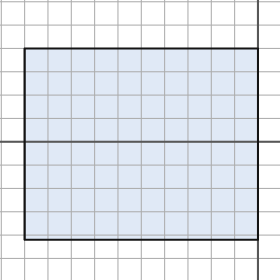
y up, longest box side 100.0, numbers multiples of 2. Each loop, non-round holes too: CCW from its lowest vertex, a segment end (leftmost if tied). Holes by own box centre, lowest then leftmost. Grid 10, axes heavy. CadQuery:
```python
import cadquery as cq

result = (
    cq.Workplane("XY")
    .moveTo(-100.0, -42.0)
    .lineTo(0.0, -42.0)
    .lineTo(0.0, 40.0)
    .lineTo(-100.0, 40.0)
    .close()
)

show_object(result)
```